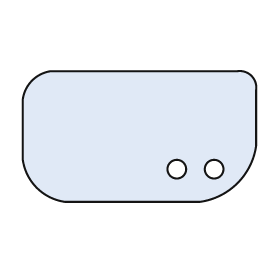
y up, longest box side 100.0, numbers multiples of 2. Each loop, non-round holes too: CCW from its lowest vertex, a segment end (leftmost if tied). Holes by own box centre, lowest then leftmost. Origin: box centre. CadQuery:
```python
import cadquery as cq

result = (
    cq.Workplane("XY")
    .moveTo(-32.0, -28.0)
    .lineTo(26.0, -28.0)
    .threePointArc((42.0, -20.0), (50.0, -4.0))
    .lineTo(50.0, 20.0)
    .threePointArc((48.0, 26.0), (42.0, 28.0))
    .lineTo(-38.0, 28.0)
    .threePointArc((-46.0, 24.0), (-50.0, 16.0))
    .lineTo(-50.0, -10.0)
    .threePointArc((-44.0, -22.0), (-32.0, -28.0))
    .close()
    .moveTo(16.0, -14.0)
    .circle(4.0)
    .moveTo(32.0, -14.0)
    .circle(4.0)
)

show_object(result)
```